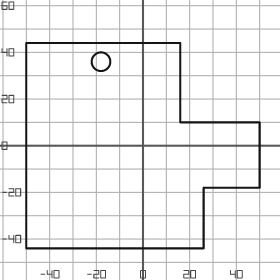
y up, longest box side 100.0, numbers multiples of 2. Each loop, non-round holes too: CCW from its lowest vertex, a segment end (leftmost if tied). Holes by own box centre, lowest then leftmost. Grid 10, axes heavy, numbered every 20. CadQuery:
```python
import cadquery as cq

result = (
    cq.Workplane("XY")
    .moveTo(-50.0, -44.0)
    .lineTo(26.0, -44.0)
    .lineTo(26.0, -18.0)
    .lineTo(50.0, -18.0)
    .lineTo(50.0, 10.0)
    .lineTo(16.0, 10.0)
    .lineTo(16.0, 44.0)
    .lineTo(-50.0, 44.0)
    .close()
    .moveTo(-18.0, 36.0)
    .circle(4.0)
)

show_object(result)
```